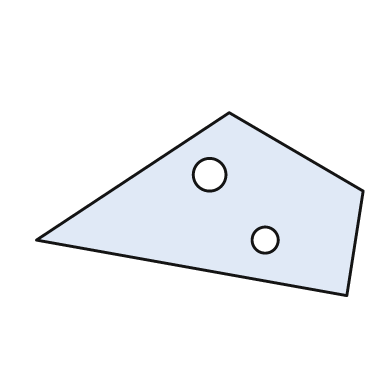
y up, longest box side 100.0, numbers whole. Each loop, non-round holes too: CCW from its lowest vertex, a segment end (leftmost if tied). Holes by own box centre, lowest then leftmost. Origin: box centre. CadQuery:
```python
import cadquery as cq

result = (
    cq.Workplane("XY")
    .moveTo(45.0, -28.0)
    .lineTo(50.0, 4.0)
    .lineTo(9.0, 28.0)
    .lineTo(-50.0, -11.0)
    .close()
    .moveTo(20.0, -11.0)
    .circle(4.0)
    .moveTo(3.0, 9.0)
    .circle(5.0)
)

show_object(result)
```